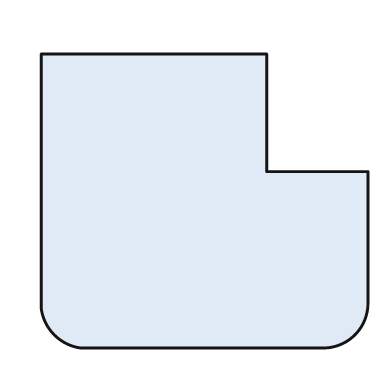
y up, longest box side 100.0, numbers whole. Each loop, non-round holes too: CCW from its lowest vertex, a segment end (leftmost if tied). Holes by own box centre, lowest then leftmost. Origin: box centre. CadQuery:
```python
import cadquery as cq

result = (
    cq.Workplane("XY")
    .moveTo(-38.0, -45.0)
    .lineTo(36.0, -45.0)
    .threePointArc((46.0, -41.0), (50.0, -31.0))
    .lineTo(50.0, 9.0)
    .lineTo(19.0, 9.0)
    .lineTo(19.0, 45.0)
    .lineTo(-50.0, 45.0)
    .lineTo(-50.0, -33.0)
    .threePointArc((-46.0, -41.0), (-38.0, -45.0))
    .close()
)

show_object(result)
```